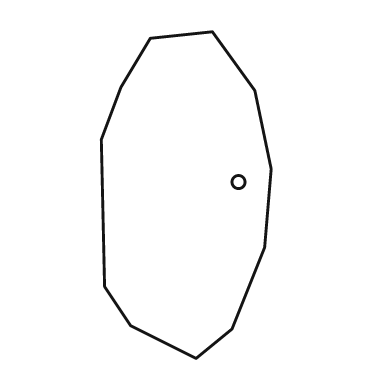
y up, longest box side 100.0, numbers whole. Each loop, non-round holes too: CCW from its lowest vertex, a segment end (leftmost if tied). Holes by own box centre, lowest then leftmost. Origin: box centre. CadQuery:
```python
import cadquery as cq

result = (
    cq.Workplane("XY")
    .moveTo(3.0, -50.0)
    .lineTo(14.0, -41.0)
    .lineTo(24.0, -16.0)
    .lineTo(26.0, 8.0)
    .lineTo(21.0, 32.0)
    .lineTo(8.0, 50.0)
    .lineTo(-11.0, 48.0)
    .lineTo(-20.0, 33.0)
    .lineTo(-26.0, 17.0)
    .lineTo(-25.0, -28.0)
    .lineTo(-17.0, -40.0)
    .close()
    .moveTo(16.0, 4.0)
    .circle(2.0)
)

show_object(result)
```